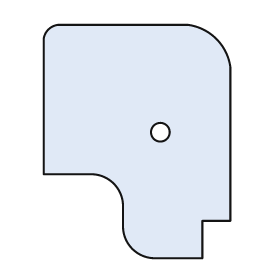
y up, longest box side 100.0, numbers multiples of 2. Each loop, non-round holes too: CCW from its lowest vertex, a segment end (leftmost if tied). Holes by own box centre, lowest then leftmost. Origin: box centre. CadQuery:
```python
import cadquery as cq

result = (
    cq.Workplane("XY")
    .moveTo(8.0, -50.0)
    .lineTo(28.0, -50.0)
    .lineTo(28.0, -34.0)
    .lineTo(40.0, -34.0)
    .lineTo(40.0, 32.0)
    .threePointArc((34.0, 44.0), (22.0, 50.0))
    .lineTo(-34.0, 50.0)
    .threePointArc((-38.0, 48.0), (-40.0, 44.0))
    .lineTo(-40.0, -14.0)
    .lineTo(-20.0, -14.0)
    .threePointArc((-10.0, -18.0), (-6.0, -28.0))
    .lineTo(-6.0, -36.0)
    .threePointArc((-2.0, -46.0), (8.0, -50.0))
    .close()
    .moveTo(10.0, 4.0)
    .circle(4.0)
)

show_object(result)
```